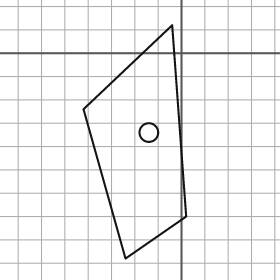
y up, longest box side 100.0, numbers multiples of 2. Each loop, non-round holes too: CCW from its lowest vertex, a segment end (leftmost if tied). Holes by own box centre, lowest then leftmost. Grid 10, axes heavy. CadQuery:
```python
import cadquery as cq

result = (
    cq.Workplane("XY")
    .moveTo(-24.0, -88.0)
    .lineTo(2.0, -70.0)
    .lineTo(-4.0, 12.0)
    .lineTo(-42.0, -24.0)
    .close()
    .moveTo(-14.0, -34.0)
    .circle(4.0)
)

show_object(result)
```